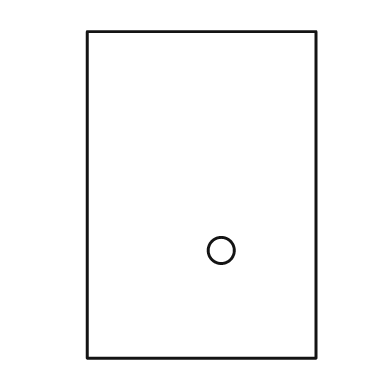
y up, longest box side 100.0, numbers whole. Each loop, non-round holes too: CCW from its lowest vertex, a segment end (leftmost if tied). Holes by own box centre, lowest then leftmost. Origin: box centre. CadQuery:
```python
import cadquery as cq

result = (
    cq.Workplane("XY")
    .moveTo(-35.0, -50.0)
    .lineTo(35.0, -50.0)
    .lineTo(35.0, 50.0)
    .lineTo(-35.0, 50.0)
    .close()
    .moveTo(6.0, -17.0)
    .circle(4.0)
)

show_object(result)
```